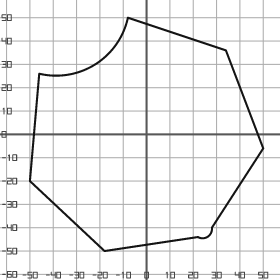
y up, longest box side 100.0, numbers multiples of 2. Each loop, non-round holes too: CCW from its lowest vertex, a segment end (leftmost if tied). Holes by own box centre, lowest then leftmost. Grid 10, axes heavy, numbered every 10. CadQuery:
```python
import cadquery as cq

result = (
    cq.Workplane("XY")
    .moveTo(-18.0, -50.0)
    .lineTo(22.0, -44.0)
    .threePointArc((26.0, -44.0), (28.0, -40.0))
    .lineTo(50.0, -6.0)
    .lineTo(34.0, 36.0)
    .lineTo(-8.0, 50.0)
    .threePointArc((-22.0, 30.0), (-46.0, 26.0))
    .lineTo(-50.0, -20.0)
    .close()
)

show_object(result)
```